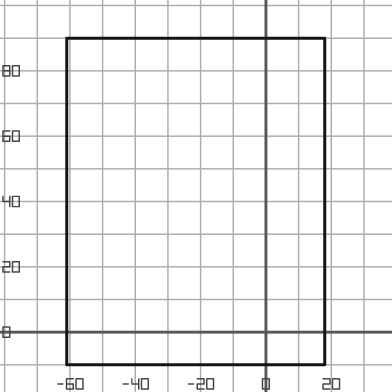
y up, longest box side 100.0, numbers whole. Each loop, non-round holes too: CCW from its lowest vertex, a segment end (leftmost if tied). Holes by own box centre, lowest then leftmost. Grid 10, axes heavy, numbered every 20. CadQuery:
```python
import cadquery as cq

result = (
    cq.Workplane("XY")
    .moveTo(-61.0, -10.0)
    .lineTo(18.0, -10.0)
    .lineTo(18.0, 90.0)
    .lineTo(-61.0, 90.0)
    .close()
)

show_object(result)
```